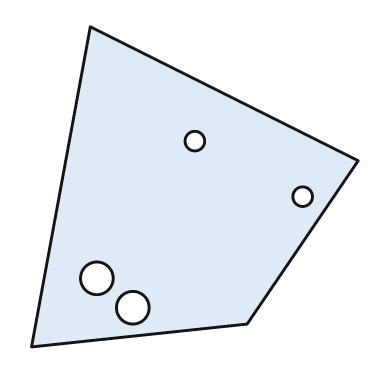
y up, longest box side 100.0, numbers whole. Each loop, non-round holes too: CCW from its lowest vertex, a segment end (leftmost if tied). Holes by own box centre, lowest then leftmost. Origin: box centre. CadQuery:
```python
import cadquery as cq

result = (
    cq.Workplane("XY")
    .moveTo(-50.0, -49.0)
    .lineTo(16.0, -42.0)
    .lineTo(50.0, 8.0)
    .lineTo(-32.0, 49.0)
    .close()
    .moveTo(-19.0, -37.0)
    .circle(5.0)
    .moveTo(-30.0, -28.0)
    .circle(5.0)
    .moveTo(33.0, -3.0)
    .circle(3.0)
    .moveTo(0.0, 14.0)
    .circle(3.0)
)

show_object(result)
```